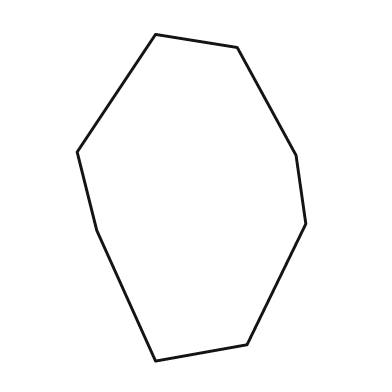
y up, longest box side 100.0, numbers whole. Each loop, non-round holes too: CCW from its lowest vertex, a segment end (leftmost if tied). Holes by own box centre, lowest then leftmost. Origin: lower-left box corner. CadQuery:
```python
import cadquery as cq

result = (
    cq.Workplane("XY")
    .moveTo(24.0, 0.0)
    .lineTo(52.0, 5.0)
    .lineTo(70.0, 42.0)
    .lineTo(67.0, 63.0)
    .lineTo(49.0, 96.0)
    .lineTo(24.0, 100.0)
    .lineTo(0.0, 64.0)
    .lineTo(6.0, 40.0)
    .close()
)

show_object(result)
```